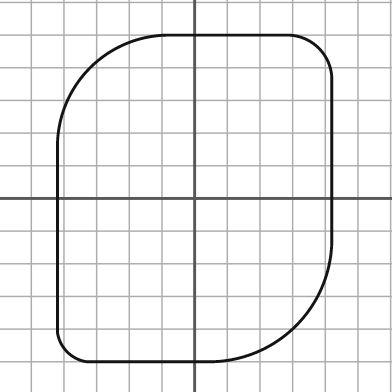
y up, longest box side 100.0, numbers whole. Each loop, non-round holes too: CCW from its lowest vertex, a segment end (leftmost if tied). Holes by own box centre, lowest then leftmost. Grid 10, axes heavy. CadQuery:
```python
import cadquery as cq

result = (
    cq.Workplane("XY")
    .moveTo(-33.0, -50.0)
    .lineTo(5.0, -50.0)
    .threePointArc((31.0, -39.0), (42.0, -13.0))
    .lineTo(42.0, 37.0)
    .threePointArc((38.0, 46.0), (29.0, 50.0))
    .lineTo(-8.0, 50.0)
    .threePointArc((-32.0, 40.0), (-42.0, 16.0))
    .lineTo(-42.0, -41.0)
    .threePointArc((-39.0, -47.0), (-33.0, -50.0))
    .close()
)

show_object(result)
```